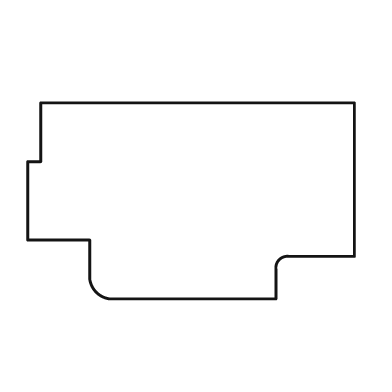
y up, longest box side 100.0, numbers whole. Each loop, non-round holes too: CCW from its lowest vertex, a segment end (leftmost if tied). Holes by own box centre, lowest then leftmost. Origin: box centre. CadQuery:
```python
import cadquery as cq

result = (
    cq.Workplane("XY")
    .moveTo(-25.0, -30.0)
    .lineTo(26.0, -30.0)
    .lineTo(26.0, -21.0)
    .threePointArc((27.0, -18.0), (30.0, -17.0))
    .lineTo(50.0, -17.0)
    .lineTo(50.0, 30.0)
    .lineTo(-46.0, 30.0)
    .lineTo(-46.0, 12.0)
    .lineTo(-50.0, 12.0)
    .lineTo(-50.0, -12.0)
    .lineTo(-31.0, -12.0)
    .lineTo(-31.0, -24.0)
    .threePointArc((-29.0, -28.0), (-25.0, -30.0))
    .close()
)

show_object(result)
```